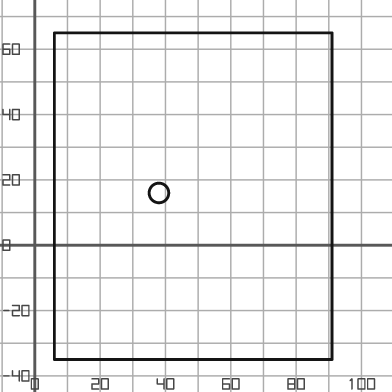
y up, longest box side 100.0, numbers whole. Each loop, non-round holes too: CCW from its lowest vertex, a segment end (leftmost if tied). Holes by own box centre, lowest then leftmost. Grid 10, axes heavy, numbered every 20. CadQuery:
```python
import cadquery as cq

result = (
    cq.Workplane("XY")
    .moveTo(6.0, -35.0)
    .lineTo(91.0, -35.0)
    .lineTo(91.0, 65.0)
    .lineTo(6.0, 65.0)
    .close()
    .moveTo(38.0, 16.0)
    .circle(3.0)
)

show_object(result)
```